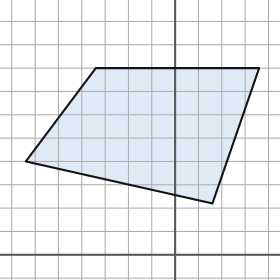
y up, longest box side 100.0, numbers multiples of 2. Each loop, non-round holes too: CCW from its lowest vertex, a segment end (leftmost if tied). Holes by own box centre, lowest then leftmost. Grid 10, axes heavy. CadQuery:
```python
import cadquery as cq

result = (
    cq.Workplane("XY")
    .moveTo(16.0, 22.0)
    .lineTo(36.0, 80.0)
    .lineTo(-34.0, 80.0)
    .lineTo(-64.0, 40.0)
    .close()
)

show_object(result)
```